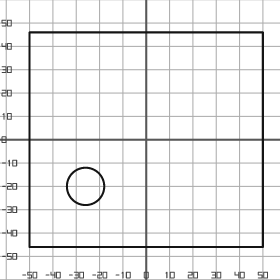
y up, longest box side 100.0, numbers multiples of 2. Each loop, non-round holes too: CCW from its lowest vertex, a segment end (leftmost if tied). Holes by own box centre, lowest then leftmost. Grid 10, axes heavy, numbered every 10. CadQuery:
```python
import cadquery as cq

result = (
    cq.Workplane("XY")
    .moveTo(-50.0, -46.0)
    .lineTo(50.0, -46.0)
    .lineTo(50.0, 46.0)
    .lineTo(-50.0, 46.0)
    .close()
    .moveTo(-26.0, -20.0)
    .circle(8.0)
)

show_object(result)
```